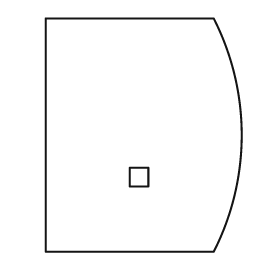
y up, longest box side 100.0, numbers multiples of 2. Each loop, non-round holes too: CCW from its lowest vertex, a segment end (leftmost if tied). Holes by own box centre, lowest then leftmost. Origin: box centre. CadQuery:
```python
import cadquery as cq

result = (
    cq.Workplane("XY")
    .moveTo(-42.0, -50.0)
    .lineTo(30.0, -50.0)
    .threePointArc((42.0, 0.0), (30.0, 50.0))
    .lineTo(-42.0, 50.0)
    .close()
    .moveTo(-6.0, -22.0)
    .lineTo(2.0, -22.0)
    .lineTo(2.0, -14.0)
    .lineTo(-6.0, -14.0)
    .close()
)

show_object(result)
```